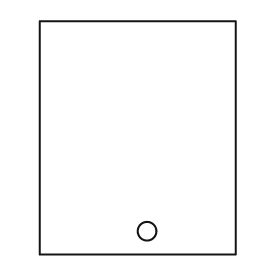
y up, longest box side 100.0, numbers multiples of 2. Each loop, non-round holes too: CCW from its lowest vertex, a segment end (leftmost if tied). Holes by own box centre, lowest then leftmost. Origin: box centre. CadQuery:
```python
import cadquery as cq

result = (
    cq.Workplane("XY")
    .moveTo(-42.0, -50.0)
    .lineTo(42.0, -50.0)
    .lineTo(42.0, 50.0)
    .lineTo(-42.0, 50.0)
    .close()
    .moveTo(4.0, -40.0)
    .circle(4.0)
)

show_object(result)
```